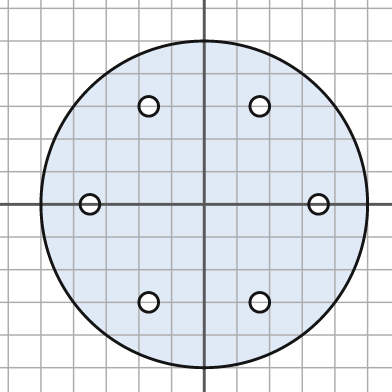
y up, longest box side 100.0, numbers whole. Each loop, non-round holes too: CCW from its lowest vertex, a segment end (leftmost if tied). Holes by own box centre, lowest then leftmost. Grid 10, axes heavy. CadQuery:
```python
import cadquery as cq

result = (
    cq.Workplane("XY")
    .moveTo(0.0, 0.0)
    .circle(50.0)
    .moveTo(-17.0, -30.0)
    .circle(3.0)
    .moveTo(17.0, -30.0)
    .circle(3.0)
    .moveTo(-35.0, 0.0)
    .circle(3.0)
    .moveTo(35.0, 0.0)
    .circle(3.0)
    .moveTo(-17.0, 30.0)
    .circle(3.0)
    .moveTo(17.0, 30.0)
    .circle(3.0)
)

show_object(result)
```